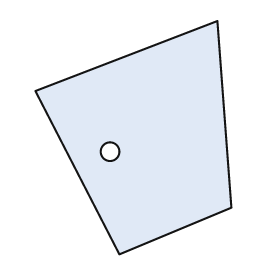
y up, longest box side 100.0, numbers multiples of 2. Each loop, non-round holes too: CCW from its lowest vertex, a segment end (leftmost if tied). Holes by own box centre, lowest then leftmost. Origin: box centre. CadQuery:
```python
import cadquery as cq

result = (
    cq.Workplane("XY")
    .moveTo(-6.0, -50.0)
    .lineTo(42.0, -30.0)
    .lineTo(36.0, 50.0)
    .lineTo(-42.0, 20.0)
    .close()
    .moveTo(-10.0, -6.0)
    .circle(4.0)
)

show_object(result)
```